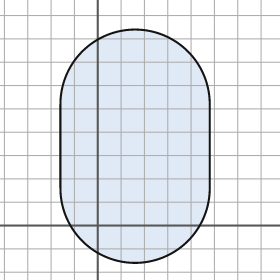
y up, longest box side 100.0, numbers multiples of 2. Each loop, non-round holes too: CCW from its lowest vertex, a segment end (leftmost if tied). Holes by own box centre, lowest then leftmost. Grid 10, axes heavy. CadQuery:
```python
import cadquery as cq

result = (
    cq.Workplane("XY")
    .moveTo(-16.0, 16.0)
    .threePointArc((16.0, -16.0), (48.0, 16.0))
    .lineTo(48.0, 52.0)
    .threePointArc((16.0, 84.0), (-16.0, 52.0))
    .close()
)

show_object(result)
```